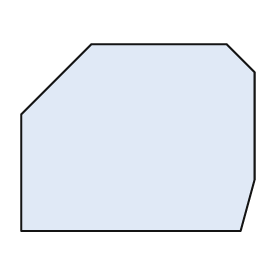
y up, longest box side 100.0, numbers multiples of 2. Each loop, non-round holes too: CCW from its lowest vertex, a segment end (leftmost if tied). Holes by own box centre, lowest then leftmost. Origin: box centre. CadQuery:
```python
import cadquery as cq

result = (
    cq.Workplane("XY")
    .moveTo(-50.0, -40.0)
    .lineTo(44.0, -40.0)
    .lineTo(50.0, -18.0)
    .lineTo(50.0, 28.0)
    .lineTo(38.0, 40.0)
    .lineTo(-20.0, 40.0)
    .lineTo(-50.0, 10.0)
    .close()
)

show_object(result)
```